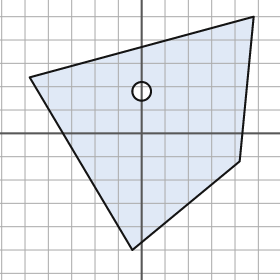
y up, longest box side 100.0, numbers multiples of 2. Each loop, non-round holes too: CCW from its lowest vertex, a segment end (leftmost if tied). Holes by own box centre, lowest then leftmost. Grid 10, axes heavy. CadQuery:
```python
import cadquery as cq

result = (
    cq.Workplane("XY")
    .moveTo(-4.0, -50.0)
    .lineTo(42.0, -12.0)
    .lineTo(48.0, 50.0)
    .lineTo(-48.0, 24.0)
    .close()
    .moveTo(0.0, 18.0)
    .circle(4.0)
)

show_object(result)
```